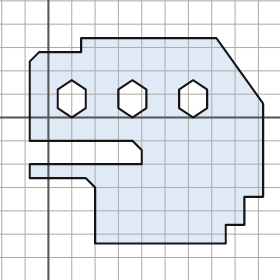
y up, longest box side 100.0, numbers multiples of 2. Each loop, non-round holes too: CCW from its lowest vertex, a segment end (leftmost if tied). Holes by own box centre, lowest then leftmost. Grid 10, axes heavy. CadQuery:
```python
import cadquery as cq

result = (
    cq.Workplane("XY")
    .moveTo(20.0, -54.0)
    .lineTo(76.0, -54.0)
    .lineTo(76.0, -46.0)
    .lineTo(84.0, -46.0)
    .lineTo(84.0, -34.0)
    .lineTo(92.0, -34.0)
    .lineTo(92.0, 6.0)
    .lineTo(72.0, 34.0)
    .lineTo(14.0, 34.0)
    .lineTo(14.0, 28.0)
    .lineTo(-4.0, 28.0)
    .lineTo(-8.0, 24.0)
    .lineTo(-8.0, -10.0)
    .lineTo(36.0, -10.0)
    .lineTo(40.0, -14.0)
    .lineTo(40.0, -20.0)
    .lineTo(-8.0, -20.0)
    .lineTo(-8.0, -26.0)
    .lineTo(16.0, -26.0)
    .lineTo(20.0, -30.0)
    .close()
    .moveTo(10.0, 0.0)
    .lineTo(16.0, 4.0)
    .lineTo(16.0, 12.0)
    .lineTo(10.0, 16.0)
    .lineTo(4.0, 12.0)
    .lineTo(4.0, 4.0)
    .close()
    .moveTo(36.0, 0.0)
    .lineTo(42.0, 4.0)
    .lineTo(42.0, 12.0)
    .lineTo(36.0, 16.0)
    .lineTo(30.0, 12.0)
    .lineTo(30.0, 4.0)
    .close()
    .moveTo(62.0, 0.0)
    .lineTo(68.0, 4.0)
    .lineTo(68.0, 12.0)
    .lineTo(62.0, 16.0)
    .lineTo(56.0, 12.0)
    .lineTo(56.0, 4.0)
    .close()
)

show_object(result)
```